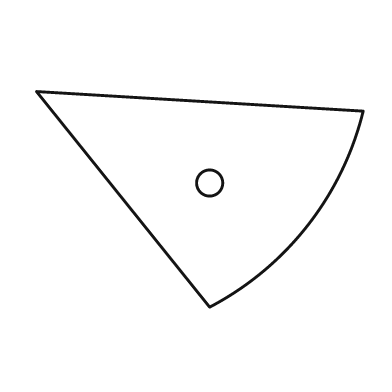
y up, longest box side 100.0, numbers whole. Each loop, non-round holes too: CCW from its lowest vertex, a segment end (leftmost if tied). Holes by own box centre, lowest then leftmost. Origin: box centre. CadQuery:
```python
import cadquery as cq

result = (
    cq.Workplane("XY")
    .moveTo(3.0, -33.0)
    .threePointArc((33.0, -8.0), (50.0, 27.0))
    .lineTo(-50.0, 33.0)
    .close()
    .moveTo(3.0, 5.0)
    .circle(4.0)
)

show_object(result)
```